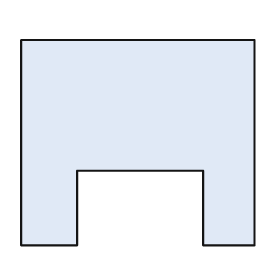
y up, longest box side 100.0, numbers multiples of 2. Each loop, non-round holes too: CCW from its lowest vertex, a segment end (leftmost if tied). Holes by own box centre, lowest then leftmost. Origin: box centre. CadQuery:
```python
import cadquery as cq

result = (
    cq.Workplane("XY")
    .moveTo(-50.0, -44.0)
    .lineTo(-26.0, -44.0)
    .lineTo(-26.0, -12.0)
    .lineTo(28.0, -12.0)
    .lineTo(28.0, -44.0)
    .lineTo(50.0, -44.0)
    .lineTo(50.0, 44.0)
    .lineTo(-50.0, 44.0)
    .close()
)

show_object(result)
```